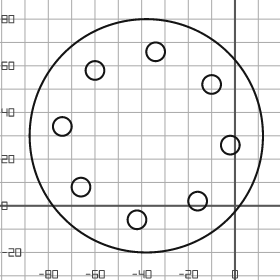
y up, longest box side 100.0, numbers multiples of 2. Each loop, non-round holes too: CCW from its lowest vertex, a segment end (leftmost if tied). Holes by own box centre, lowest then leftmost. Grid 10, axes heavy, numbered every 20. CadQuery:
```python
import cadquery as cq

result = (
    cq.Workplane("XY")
    .moveTo(-38.0, 30.0)
    .circle(50.0)
    .moveTo(-42.0, -6.0)
    .circle(4.0)
    .moveTo(-16.0, 2.0)
    .circle(4.0)
    .moveTo(-66.0, 8.0)
    .circle(4.0)
    .moveTo(-2.0, 26.0)
    .circle(4.0)
    .moveTo(-74.0, 34.0)
    .circle(4.0)
    .moveTo(-10.0, 52.0)
    .circle(4.0)
    .moveTo(-60.0, 58.0)
    .circle(4.0)
    .moveTo(-34.0, 66.0)
    .circle(4.0)
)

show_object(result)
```